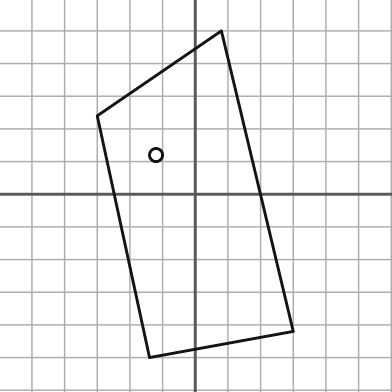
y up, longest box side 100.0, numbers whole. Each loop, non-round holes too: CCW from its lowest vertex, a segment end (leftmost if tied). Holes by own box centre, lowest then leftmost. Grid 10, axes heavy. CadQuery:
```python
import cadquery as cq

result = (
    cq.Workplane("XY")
    .moveTo(-14.0, -50.0)
    .lineTo(30.0, -42.0)
    .lineTo(8.0, 50.0)
    .lineTo(-30.0, 24.0)
    .close()
    .moveTo(-12.0, 12.0)
    .circle(2.0)
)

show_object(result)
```